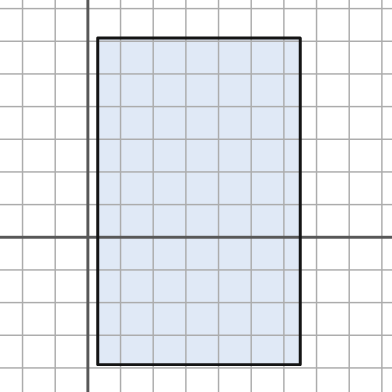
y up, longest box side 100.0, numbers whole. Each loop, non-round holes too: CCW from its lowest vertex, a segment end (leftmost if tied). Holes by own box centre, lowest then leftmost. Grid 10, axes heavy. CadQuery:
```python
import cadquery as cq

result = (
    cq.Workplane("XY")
    .moveTo(3.0, -39.0)
    .lineTo(65.0, -39.0)
    .lineTo(65.0, 61.0)
    .lineTo(3.0, 61.0)
    .close()
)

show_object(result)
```